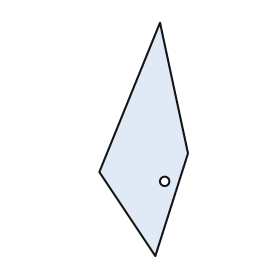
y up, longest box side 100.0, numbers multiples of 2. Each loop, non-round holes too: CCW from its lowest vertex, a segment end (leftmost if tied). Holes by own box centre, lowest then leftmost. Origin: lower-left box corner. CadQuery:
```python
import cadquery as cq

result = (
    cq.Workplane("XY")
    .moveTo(24.0, 0.0)
    .lineTo(38.0, 44.0)
    .lineTo(26.0, 100.0)
    .lineTo(0.0, 36.0)
    .close()
    .moveTo(28.0, 32.0)
    .circle(2.0)
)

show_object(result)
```